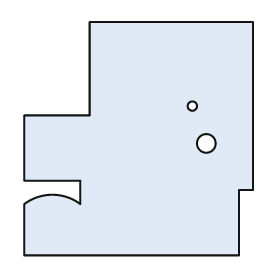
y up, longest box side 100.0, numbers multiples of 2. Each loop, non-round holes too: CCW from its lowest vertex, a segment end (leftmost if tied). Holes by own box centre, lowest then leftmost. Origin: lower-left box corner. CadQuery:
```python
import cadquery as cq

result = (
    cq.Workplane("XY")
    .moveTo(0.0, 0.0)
    .lineTo(92.0, 0.0)
    .lineTo(92.0, 28.0)
    .lineTo(98.0, 28.0)
    .lineTo(98.0, 100.0)
    .lineTo(28.0, 100.0)
    .lineTo(28.0, 60.0)
    .lineTo(0.0, 60.0)
    .lineTo(0.0, 32.0)
    .lineTo(24.0, 32.0)
    .lineTo(24.0, 22.0)
    .threePointArc((12.0, 26.0), (0.0, 22.0))
    .close()
    .moveTo(78.0, 48.0)
    .circle(4.0)
    .moveTo(72.0, 64.0)
    .circle(2.0)
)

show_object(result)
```